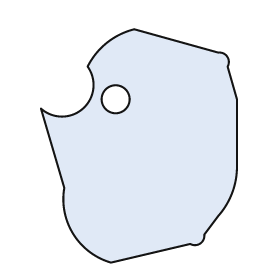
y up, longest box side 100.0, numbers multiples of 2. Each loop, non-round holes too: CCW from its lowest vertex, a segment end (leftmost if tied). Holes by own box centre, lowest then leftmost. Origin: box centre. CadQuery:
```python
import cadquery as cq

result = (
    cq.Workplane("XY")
    .moveTo(-12.0, -50.0)
    .lineTo(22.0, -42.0)
    .threePointArc((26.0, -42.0), (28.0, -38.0))
    .lineTo(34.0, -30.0)
    .threePointArc((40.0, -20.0), (42.0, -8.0))
    .lineTo(42.0, 20.0)
    .lineTo(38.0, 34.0)
    .threePointArc((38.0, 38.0), (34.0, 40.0))
    .lineTo(-2.0, 50.0)
    .threePointArc((-14.0, 44.0), (-22.0, 34.0))
    .threePointArc((-24.0, 16.0), (-42.0, 16.0))
    .lineTo(-32.0, -18.0)
    .threePointArc((-28.0, -38.0), (-12.0, -50.0))
    .close()
    .moveTo(-10.0, 20.0)
    .circle(6.0)
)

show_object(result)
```